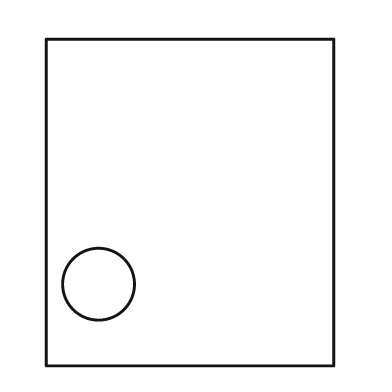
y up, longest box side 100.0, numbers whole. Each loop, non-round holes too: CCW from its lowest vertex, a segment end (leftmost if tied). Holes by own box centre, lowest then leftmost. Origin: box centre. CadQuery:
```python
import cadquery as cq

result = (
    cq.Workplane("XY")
    .moveTo(-44.0, -50.0)
    .lineTo(44.0, -50.0)
    .lineTo(44.0, 50.0)
    .lineTo(-44.0, 50.0)
    .close()
    .moveTo(-28.0, -25.0)
    .circle(11.0)
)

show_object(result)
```